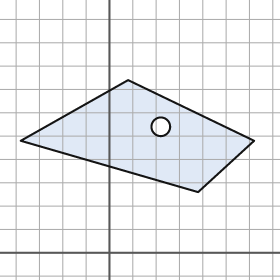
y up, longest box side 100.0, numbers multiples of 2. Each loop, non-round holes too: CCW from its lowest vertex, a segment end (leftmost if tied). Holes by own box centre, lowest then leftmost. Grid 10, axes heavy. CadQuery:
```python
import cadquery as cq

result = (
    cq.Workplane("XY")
    .moveTo(38.0, 26.0)
    .lineTo(62.0, 48.0)
    .lineTo(8.0, 74.0)
    .lineTo(-38.0, 48.0)
    .close()
    .moveTo(22.0, 54.0)
    .circle(4.0)
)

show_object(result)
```